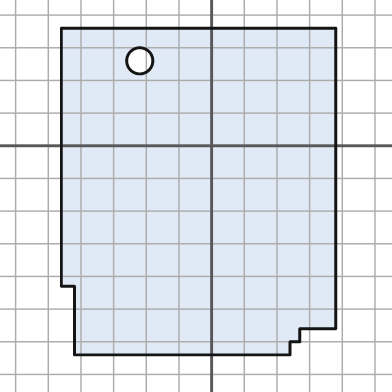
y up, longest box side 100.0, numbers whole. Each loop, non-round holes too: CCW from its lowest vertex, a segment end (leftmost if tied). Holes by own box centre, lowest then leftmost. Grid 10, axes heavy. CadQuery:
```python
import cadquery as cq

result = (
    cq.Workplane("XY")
    .moveTo(-42.0, -64.0)
    .lineTo(24.0, -64.0)
    .lineTo(24.0, -60.0)
    .lineTo(27.0, -60.0)
    .lineTo(27.0, -56.0)
    .lineTo(38.0, -56.0)
    .lineTo(38.0, 36.0)
    .lineTo(-46.0, 36.0)
    .lineTo(-46.0, -43.0)
    .lineTo(-42.0, -43.0)
    .close()
    .moveTo(-22.0, 26.0)
    .circle(4.0)
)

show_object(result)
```